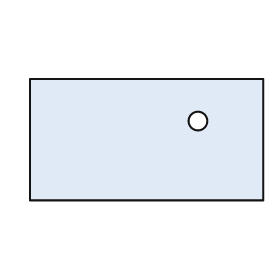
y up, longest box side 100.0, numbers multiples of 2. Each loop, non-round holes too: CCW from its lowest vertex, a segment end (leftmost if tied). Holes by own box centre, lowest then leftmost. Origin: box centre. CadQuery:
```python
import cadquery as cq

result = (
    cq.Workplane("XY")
    .moveTo(-50.0, -26.0)
    .lineTo(50.0, -26.0)
    .lineTo(50.0, 26.0)
    .lineTo(-50.0, 26.0)
    .close()
    .moveTo(22.0, 8.0)
    .circle(4.0)
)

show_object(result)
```